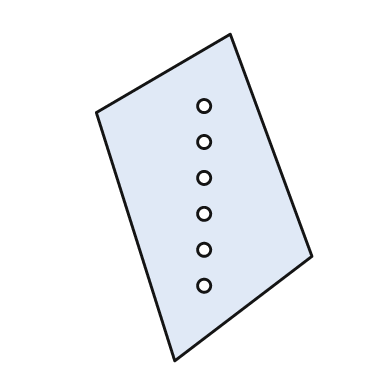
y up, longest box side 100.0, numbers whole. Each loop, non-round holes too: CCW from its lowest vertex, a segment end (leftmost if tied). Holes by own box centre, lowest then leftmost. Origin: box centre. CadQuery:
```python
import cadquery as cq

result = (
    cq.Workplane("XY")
    .moveTo(-9.0, -50.0)
    .lineTo(33.0, -18.0)
    .lineTo(8.0, 50.0)
    .lineTo(-33.0, 26.0)
    .close()
    .moveTo(0.0, -27.0)
    .circle(2.0)
    .moveTo(0.0, -16.0)
    .circle(2.0)
    .moveTo(0.0, -5.0)
    .circle(2.0)
    .moveTo(0.0, 6.0)
    .circle(2.0)
    .moveTo(0.0, 17.0)
    .circle(2.0)
    .moveTo(0.0, 28.0)
    .circle(2.0)
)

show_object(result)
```